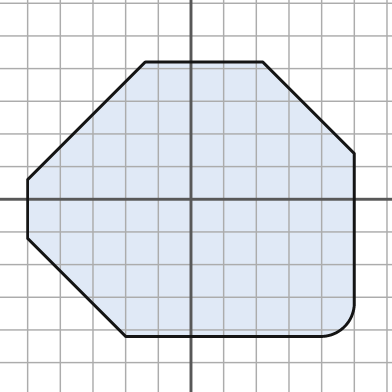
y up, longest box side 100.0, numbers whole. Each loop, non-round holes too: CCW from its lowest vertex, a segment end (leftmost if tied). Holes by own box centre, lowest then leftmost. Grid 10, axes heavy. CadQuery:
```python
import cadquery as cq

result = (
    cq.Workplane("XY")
    .moveTo(-20.0, -42.0)
    .lineTo(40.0, -42.0)
    .threePointArc((47.0, -39.0), (50.0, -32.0))
    .lineTo(50.0, 14.0)
    .lineTo(22.0, 42.0)
    .lineTo(-14.0, 42.0)
    .lineTo(-50.0, 6.0)
    .lineTo(-50.0, -12.0)
    .close()
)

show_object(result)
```